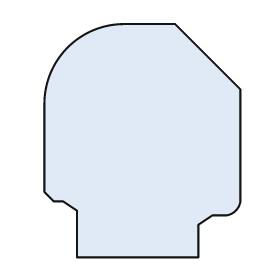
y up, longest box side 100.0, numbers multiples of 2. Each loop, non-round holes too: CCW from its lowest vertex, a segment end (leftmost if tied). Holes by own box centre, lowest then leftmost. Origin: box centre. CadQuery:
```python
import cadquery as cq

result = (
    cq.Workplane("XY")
    .moveTo(-28.0, -50.0)
    .lineTo(24.0, -50.0)
    .lineTo(24.0, -36.0)
    .lineTo(30.0, -32.0)
    .lineTo(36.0, -32.0)
    .threePointArc((40.0, -30.0), (42.0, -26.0))
    .lineTo(42.0, 22.0)
    .lineTo(14.0, 50.0)
    .lineTo(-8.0, 50.0)
    .threePointArc((-32.0, 40.0), (-42.0, 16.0))
    .lineTo(-42.0, -22.0)
    .lineTo(-38.0, -26.0)
    .lineTo(-34.0, -26.0)
    .lineTo(-28.0, -30.0)
    .close()
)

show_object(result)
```